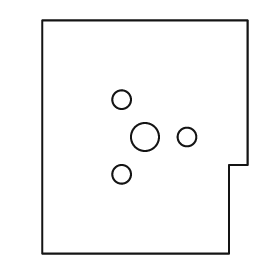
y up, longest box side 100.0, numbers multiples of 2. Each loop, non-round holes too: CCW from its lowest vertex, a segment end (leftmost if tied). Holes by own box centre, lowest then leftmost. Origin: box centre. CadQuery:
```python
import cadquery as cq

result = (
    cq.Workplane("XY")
    .moveTo(-44.0, -50.0)
    .lineTo(36.0, -50.0)
    .lineTo(36.0, -12.0)
    .lineTo(44.0, -12.0)
    .lineTo(44.0, 50.0)
    .lineTo(-44.0, 50.0)
    .close()
    .moveTo(-10.0, -16.0)
    .circle(4.0)
    .moveTo(0.0, 0.0)
    .circle(6.0)
    .moveTo(18.0, 0.0)
    .circle(4.0)
    .moveTo(-10.0, 16.0)
    .circle(4.0)
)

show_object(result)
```